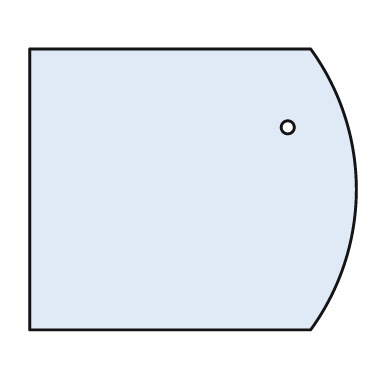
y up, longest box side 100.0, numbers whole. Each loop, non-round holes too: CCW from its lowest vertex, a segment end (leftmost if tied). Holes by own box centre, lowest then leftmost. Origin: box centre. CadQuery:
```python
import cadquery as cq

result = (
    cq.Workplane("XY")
    .moveTo(-50.0, -43.0)
    .lineTo(36.0, -43.0)
    .threePointArc((50.0, 0.0), (36.0, 43.0))
    .lineTo(-50.0, 43.0)
    .close()
    .moveTo(29.0, 19.0)
    .circle(2.0)
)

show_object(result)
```